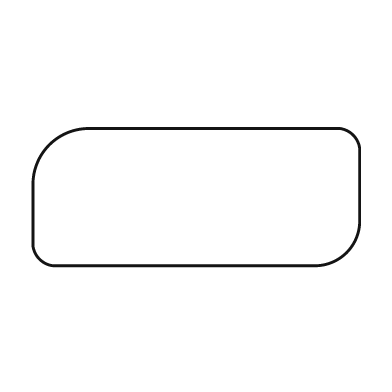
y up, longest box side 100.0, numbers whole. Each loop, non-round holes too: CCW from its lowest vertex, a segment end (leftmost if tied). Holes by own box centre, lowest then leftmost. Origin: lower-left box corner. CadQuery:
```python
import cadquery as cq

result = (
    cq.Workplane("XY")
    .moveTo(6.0, 0.0)
    .lineTo(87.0, 0.0)
    .threePointArc((96.0, 4.0), (100.0, 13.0))
    .lineTo(100.0, 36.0)
    .threePointArc((98.0, 40.0), (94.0, 42.0))
    .lineTo(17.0, 42.0)
    .threePointArc((5.0, 37.0), (0.0, 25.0))
    .lineTo(0.0, 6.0)
    .threePointArc((2.0, 2.0), (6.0, 0.0))
    .close()
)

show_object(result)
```